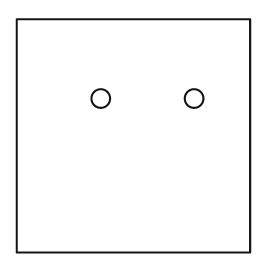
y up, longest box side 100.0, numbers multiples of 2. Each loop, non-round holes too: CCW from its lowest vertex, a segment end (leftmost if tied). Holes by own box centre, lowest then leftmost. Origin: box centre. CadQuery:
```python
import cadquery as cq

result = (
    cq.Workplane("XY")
    .moveTo(-50.0, -50.0)
    .lineTo(50.0, -50.0)
    .lineTo(50.0, 50.0)
    .lineTo(-50.0, 50.0)
    .close()
    .moveTo(-14.0, 16.0)
    .circle(4.0)
    .moveTo(26.0, 16.0)
    .circle(4.0)
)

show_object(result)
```